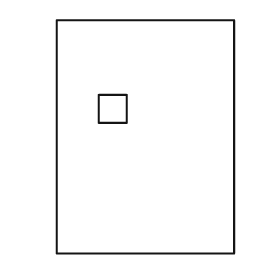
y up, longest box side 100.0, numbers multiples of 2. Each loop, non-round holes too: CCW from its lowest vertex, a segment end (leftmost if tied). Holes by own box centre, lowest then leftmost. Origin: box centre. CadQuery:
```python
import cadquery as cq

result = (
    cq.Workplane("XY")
    .moveTo(-38.0, -50.0)
    .lineTo(38.0, -50.0)
    .lineTo(38.0, 50.0)
    .lineTo(-38.0, 50.0)
    .close()
    .moveTo(-20.0, 6.0)
    .lineTo(-8.0, 6.0)
    .lineTo(-8.0, 18.0)
    .lineTo(-20.0, 18.0)
    .close()
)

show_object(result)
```